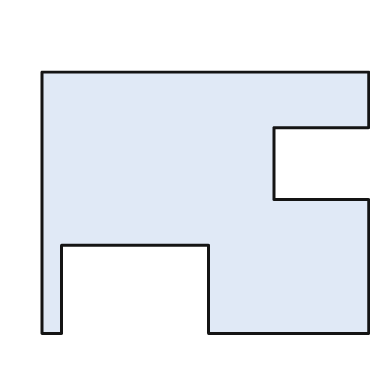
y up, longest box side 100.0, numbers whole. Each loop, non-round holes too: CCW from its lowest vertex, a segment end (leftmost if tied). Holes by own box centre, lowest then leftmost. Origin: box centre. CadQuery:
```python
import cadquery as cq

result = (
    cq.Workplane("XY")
    .moveTo(-50.0, -40.0)
    .lineTo(-44.0, -40.0)
    .lineTo(-44.0, -13.0)
    .lineTo(1.0, -13.0)
    .lineTo(1.0, -40.0)
    .lineTo(50.0, -40.0)
    .lineTo(50.0, 1.0)
    .lineTo(21.0, 1.0)
    .lineTo(21.0, 23.0)
    .lineTo(50.0, 23.0)
    .lineTo(50.0, 40.0)
    .lineTo(-50.0, 40.0)
    .close()
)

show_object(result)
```